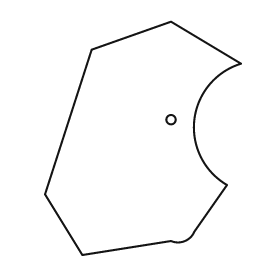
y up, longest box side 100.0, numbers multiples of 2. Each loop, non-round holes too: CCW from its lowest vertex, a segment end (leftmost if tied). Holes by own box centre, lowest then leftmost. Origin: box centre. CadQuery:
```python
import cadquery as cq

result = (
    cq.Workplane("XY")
    .moveTo(-26.0, -50.0)
    .lineTo(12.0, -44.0)
    .threePointArc((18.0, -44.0), (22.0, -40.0))
    .lineTo(36.0, -20.0)
    .threePointArc((22.0, 8.0), (42.0, 32.0))
    .lineTo(12.0, 50.0)
    .lineTo(-22.0, 38.0)
    .lineTo(-42.0, -24.0)
    .close()
    .moveTo(12.0, 8.0)
    .circle(2.0)
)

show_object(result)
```